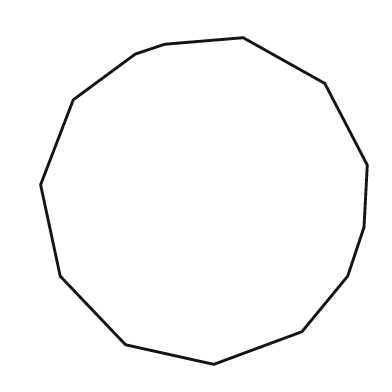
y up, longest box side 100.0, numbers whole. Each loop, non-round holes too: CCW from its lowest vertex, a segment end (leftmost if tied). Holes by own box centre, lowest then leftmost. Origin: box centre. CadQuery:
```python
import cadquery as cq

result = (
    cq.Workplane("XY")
    .moveTo(3.0, -50.0)
    .lineTo(30.0, -40.0)
    .lineTo(44.0, -23.0)
    .lineTo(49.0, -8.0)
    .lineTo(50.0, 11.0)
    .lineTo(37.0, 36.0)
    .lineTo(12.0, 50.0)
    .lineTo(-12.0, 48.0)
    .lineTo(-21.0, 45.0)
    .lineTo(-40.0, 31.0)
    .lineTo(-50.0, 5.0)
    .lineTo(-44.0, -23.0)
    .lineTo(-24.0, -44.0)
    .close()
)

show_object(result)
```